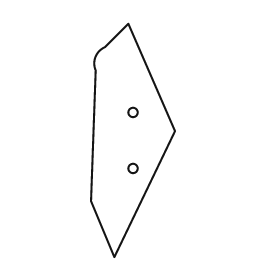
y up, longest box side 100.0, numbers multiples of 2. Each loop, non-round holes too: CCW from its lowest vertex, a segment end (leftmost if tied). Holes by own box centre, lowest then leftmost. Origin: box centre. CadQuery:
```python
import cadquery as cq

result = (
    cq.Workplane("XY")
    .moveTo(-8.0, -50.0)
    .lineTo(18.0, 4.0)
    .lineTo(-2.0, 50.0)
    .lineTo(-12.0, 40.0)
    .threePointArc((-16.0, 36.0), (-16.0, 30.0))
    .lineTo(-18.0, -26.0)
    .close()
    .moveTo(0.0, -12.0)
    .circle(2.0)
    .moveTo(0.0, 12.0)
    .circle(2.0)
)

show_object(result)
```